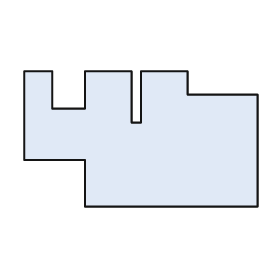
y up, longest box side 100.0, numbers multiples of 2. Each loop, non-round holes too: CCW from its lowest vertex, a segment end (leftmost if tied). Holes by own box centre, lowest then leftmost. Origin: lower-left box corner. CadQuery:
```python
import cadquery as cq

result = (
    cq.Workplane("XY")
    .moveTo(26.0, 0.0)
    .lineTo(100.0, 0.0)
    .lineTo(100.0, 48.0)
    .lineTo(70.0, 48.0)
    .lineTo(70.0, 58.0)
    .lineTo(50.0, 58.0)
    .lineTo(50.0, 36.0)
    .lineTo(46.0, 36.0)
    .lineTo(46.0, 58.0)
    .lineTo(26.0, 58.0)
    .lineTo(26.0, 42.0)
    .lineTo(12.0, 42.0)
    .lineTo(12.0, 58.0)
    .lineTo(0.0, 58.0)
    .lineTo(0.0, 20.0)
    .lineTo(26.0, 20.0)
    .close()
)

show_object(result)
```